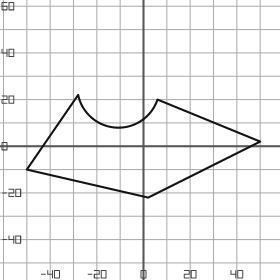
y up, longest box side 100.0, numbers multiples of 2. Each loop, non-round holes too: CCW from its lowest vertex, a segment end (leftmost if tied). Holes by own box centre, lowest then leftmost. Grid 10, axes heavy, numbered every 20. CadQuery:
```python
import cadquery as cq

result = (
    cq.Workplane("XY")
    .moveTo(2.0, -22.0)
    .lineTo(50.0, 2.0)
    .lineTo(6.0, 20.0)
    .threePointArc((-12.0, 8.0), (-28.0, 22.0))
    .lineTo(-50.0, -10.0)
    .close()
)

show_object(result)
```